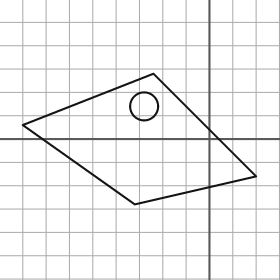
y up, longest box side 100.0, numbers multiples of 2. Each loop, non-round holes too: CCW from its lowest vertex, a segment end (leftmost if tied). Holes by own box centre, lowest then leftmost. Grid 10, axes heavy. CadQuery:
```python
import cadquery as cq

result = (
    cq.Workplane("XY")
    .moveTo(-32.0, -28.0)
    .lineTo(20.0, -16.0)
    .lineTo(-24.0, 28.0)
    .lineTo(-80.0, 6.0)
    .close()
    .moveTo(-28.0, 14.0)
    .circle(6.0)
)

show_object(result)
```